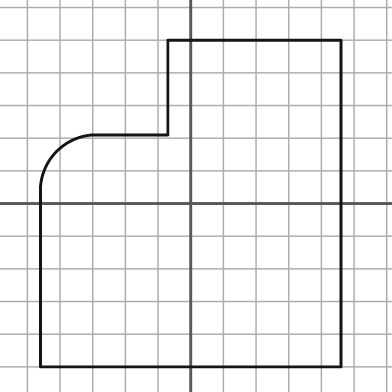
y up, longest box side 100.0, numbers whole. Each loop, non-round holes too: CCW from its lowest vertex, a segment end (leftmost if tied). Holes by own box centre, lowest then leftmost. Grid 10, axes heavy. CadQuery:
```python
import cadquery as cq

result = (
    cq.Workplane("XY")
    .moveTo(-46.0, -50.0)
    .lineTo(46.0, -50.0)
    .lineTo(46.0, 50.0)
    .lineTo(-7.0, 50.0)
    .lineTo(-7.0, 21.0)
    .lineTo(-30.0, 21.0)
    .threePointArc((-41.0, 16.0), (-46.0, 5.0))
    .close()
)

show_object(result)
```